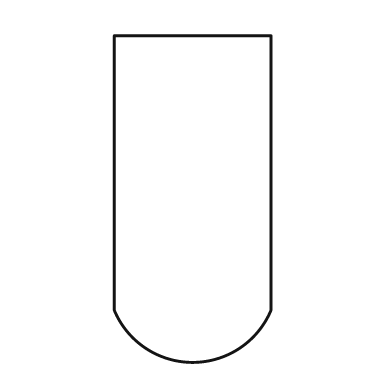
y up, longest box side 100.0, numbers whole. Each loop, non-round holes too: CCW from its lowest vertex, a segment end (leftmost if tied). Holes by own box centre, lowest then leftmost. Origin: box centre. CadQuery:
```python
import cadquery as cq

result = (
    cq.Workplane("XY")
    .moveTo(-24.0, -34.0)
    .threePointArc((0.0, -50.0), (24.0, -34.0))
    .lineTo(24.0, 50.0)
    .lineTo(-24.0, 50.0)
    .close()
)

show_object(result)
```